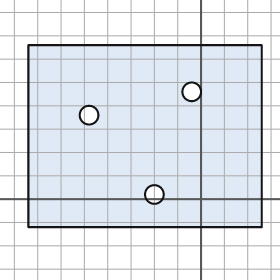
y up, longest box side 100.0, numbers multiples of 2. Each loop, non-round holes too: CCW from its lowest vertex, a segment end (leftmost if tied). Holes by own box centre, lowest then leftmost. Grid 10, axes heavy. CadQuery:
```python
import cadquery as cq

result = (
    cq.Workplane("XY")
    .moveTo(-74.0, -12.0)
    .lineTo(26.0, -12.0)
    .lineTo(26.0, 66.0)
    .lineTo(-74.0, 66.0)
    .close()
    .moveTo(-20.0, 2.0)
    .circle(4.0)
    .moveTo(-48.0, 36.0)
    .circle(4.0)
    .moveTo(-4.0, 46.0)
    .circle(4.0)
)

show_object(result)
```